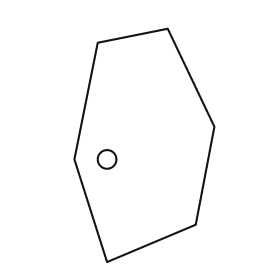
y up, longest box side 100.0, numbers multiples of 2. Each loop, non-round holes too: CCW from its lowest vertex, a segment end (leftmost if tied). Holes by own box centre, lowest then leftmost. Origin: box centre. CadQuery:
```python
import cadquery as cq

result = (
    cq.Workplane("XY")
    .moveTo(-16.0, -50.0)
    .lineTo(22.0, -34.0)
    .lineTo(30.0, 8.0)
    .lineTo(10.0, 50.0)
    .lineTo(-20.0, 44.0)
    .lineTo(-30.0, -6.0)
    .close()
    .moveTo(-16.0, -6.0)
    .circle(4.0)
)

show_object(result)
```